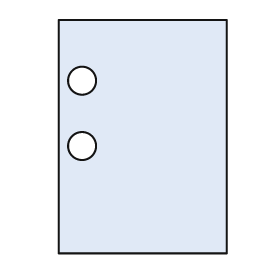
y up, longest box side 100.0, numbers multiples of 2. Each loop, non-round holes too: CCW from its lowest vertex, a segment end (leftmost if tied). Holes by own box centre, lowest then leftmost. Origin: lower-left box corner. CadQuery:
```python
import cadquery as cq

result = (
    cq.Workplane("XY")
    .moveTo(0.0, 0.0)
    .lineTo(72.0, 0.0)
    .lineTo(72.0, 100.0)
    .lineTo(0.0, 100.0)
    .close()
    .moveTo(10.0, 46.0)
    .circle(6.0)
    .moveTo(10.0, 74.0)
    .circle(6.0)
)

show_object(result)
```